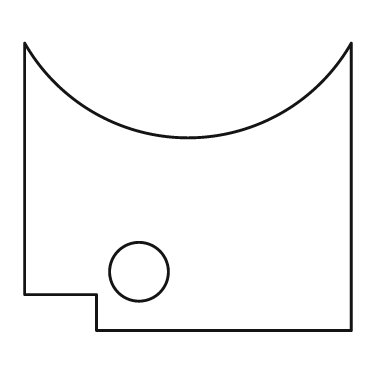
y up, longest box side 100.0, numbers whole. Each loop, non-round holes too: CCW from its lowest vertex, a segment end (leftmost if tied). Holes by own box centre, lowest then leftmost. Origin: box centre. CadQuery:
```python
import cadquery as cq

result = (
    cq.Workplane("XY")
    .moveTo(-28.0, -44.0)
    .lineTo(50.0, -44.0)
    .lineTo(50.0, 44.0)
    .threePointArc((0.0, 15.0), (-50.0, 44.0))
    .lineTo(-50.0, -33.0)
    .lineTo(-28.0, -33.0)
    .close()
    .moveTo(-15.0, -26.0)
    .circle(9.0)
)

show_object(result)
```